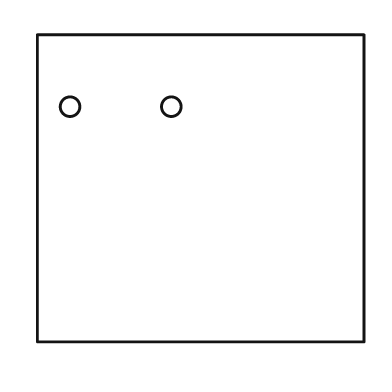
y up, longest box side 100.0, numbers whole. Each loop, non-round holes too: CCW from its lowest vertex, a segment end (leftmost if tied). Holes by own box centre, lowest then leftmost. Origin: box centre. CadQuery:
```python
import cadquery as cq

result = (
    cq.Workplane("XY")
    .moveTo(-50.0, -47.0)
    .lineTo(50.0, -47.0)
    .lineTo(50.0, 47.0)
    .lineTo(-50.0, 47.0)
    .close()
    .moveTo(-40.0, 25.0)
    .circle(3.0)
    .moveTo(-9.0, 25.0)
    .circle(3.0)
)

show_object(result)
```